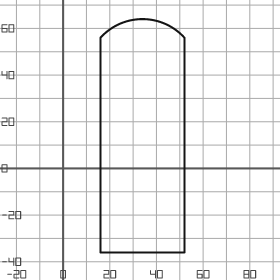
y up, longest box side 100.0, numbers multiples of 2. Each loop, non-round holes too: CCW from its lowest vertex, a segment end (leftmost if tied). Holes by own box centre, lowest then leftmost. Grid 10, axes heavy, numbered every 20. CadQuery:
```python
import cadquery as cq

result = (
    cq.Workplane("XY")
    .moveTo(16.0, -36.0)
    .lineTo(52.0, -36.0)
    .lineTo(52.0, 56.0)
    .threePointArc((34.0, 64.0), (16.0, 56.0))
    .close()
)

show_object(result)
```